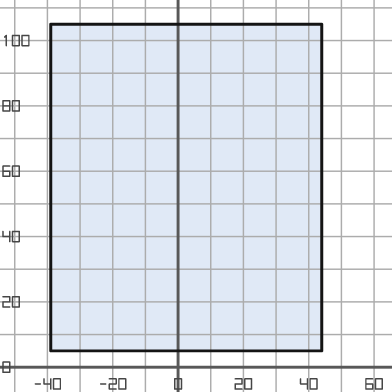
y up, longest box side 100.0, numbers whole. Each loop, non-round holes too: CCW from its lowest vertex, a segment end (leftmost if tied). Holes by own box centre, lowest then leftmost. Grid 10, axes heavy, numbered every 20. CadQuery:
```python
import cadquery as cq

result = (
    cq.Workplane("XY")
    .moveTo(-39.0, 5.0)
    .lineTo(44.0, 5.0)
    .lineTo(44.0, 105.0)
    .lineTo(-39.0, 105.0)
    .close()
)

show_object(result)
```